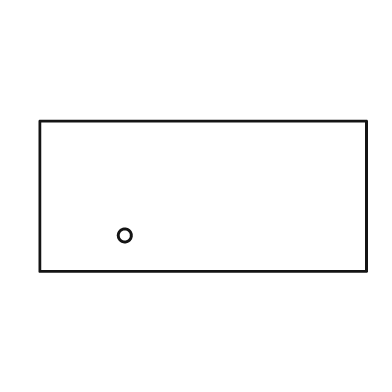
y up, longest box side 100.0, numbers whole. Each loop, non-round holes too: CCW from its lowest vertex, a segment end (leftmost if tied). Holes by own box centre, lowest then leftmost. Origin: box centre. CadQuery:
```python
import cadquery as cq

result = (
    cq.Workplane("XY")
    .moveTo(-50.0, -23.0)
    .lineTo(50.0, -23.0)
    .lineTo(50.0, 23.0)
    .lineTo(-50.0, 23.0)
    .close()
    .moveTo(-24.0, -12.0)
    .circle(2.0)
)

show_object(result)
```